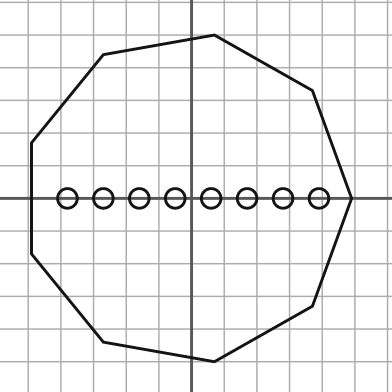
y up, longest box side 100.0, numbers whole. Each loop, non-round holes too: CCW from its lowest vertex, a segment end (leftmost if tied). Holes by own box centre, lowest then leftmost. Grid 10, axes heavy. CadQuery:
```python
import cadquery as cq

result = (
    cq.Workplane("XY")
    .moveTo(7.0, -50.0)
    .lineTo(37.0, -33.0)
    .lineTo(49.0, 0.0)
    .lineTo(37.0, 33.0)
    .lineTo(7.0, 50.0)
    .lineTo(-27.0, 44.0)
    .lineTo(-49.0, 17.0)
    .lineTo(-49.0, -17.0)
    .lineTo(-27.0, -44.0)
    .close()
    .moveTo(-38.0, 0.0)
    .circle(3.0)
    .moveTo(-27.0, 0.0)
    .circle(3.0)
    .moveTo(-16.0, 0.0)
    .circle(3.0)
    .moveTo(-5.0, 0.0)
    .circle(3.0)
    .moveTo(6.0, 0.0)
    .circle(3.0)
    .moveTo(17.0, 0.0)
    .circle(3.0)
    .moveTo(28.0, 0.0)
    .circle(3.0)
    .moveTo(39.0, 0.0)
    .circle(3.0)
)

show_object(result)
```